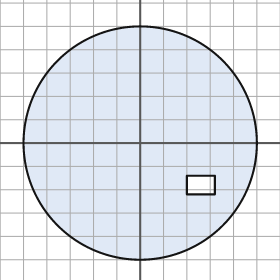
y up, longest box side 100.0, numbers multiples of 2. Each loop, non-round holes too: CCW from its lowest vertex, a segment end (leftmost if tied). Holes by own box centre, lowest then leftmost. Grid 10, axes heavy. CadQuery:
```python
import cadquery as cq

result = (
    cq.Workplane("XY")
    .moveTo(0.0, 0.0)
    .circle(50.0)
    .moveTo(20.0, -22.0)
    .lineTo(32.0, -22.0)
    .lineTo(32.0, -14.0)
    .lineTo(20.0, -14.0)
    .close()
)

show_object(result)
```